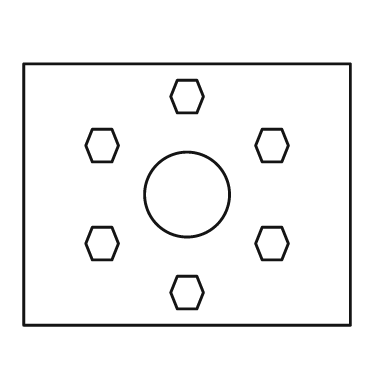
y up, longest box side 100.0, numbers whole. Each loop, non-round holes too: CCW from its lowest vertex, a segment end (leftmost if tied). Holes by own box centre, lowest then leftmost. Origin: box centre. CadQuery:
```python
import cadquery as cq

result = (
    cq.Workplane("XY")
    .moveTo(-50.0, -40.0)
    .lineTo(50.0, -40.0)
    .lineTo(50.0, 40.0)
    .lineTo(-50.0, 40.0)
    .close()
    .moveTo(-3.0, -35.0)
    .lineTo(3.0, -35.0)
    .lineTo(5.0, -30.0)
    .lineTo(3.0, -25.0)
    .lineTo(-3.0, -25.0)
    .lineTo(-5.0, -30.0)
    .close()
    .moveTo(-29.0, -20.0)
    .lineTo(-23.0, -20.0)
    .lineTo(-21.0, -15.0)
    .lineTo(-23.0, -10.0)
    .lineTo(-29.0, -10.0)
    .lineTo(-31.0, -15.0)
    .close()
    .moveTo(23.0, -20.0)
    .lineTo(29.0, -20.0)
    .lineTo(31.0, -15.0)
    .lineTo(29.0, -10.0)
    .lineTo(23.0, -10.0)
    .lineTo(21.0, -15.0)
    .close()
    .moveTo(0.0, 0.0)
    .circle(13.0)
    .moveTo(-29.0, 10.0)
    .lineTo(-23.0, 10.0)
    .lineTo(-21.0, 15.0)
    .lineTo(-23.0, 20.0)
    .lineTo(-29.0, 20.0)
    .lineTo(-31.0, 15.0)
    .close()
    .moveTo(23.0, 10.0)
    .lineTo(29.0, 10.0)
    .lineTo(31.0, 15.0)
    .lineTo(29.0, 20.0)
    .lineTo(23.0, 20.0)
    .lineTo(21.0, 15.0)
    .close()
    .moveTo(-3.0, 25.0)
    .lineTo(3.0, 25.0)
    .lineTo(5.0, 30.0)
    .lineTo(3.0, 35.0)
    .lineTo(-3.0, 35.0)
    .lineTo(-5.0, 30.0)
    .close()
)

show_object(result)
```